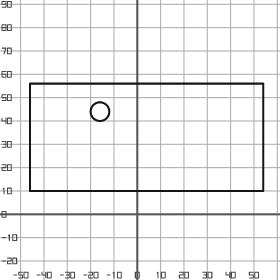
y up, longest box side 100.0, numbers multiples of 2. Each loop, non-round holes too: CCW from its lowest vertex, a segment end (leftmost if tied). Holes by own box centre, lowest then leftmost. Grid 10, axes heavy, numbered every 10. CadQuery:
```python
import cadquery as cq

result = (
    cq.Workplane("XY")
    .moveTo(-46.0, 10.0)
    .lineTo(54.0, 10.0)
    .lineTo(54.0, 56.0)
    .lineTo(-46.0, 56.0)
    .close()
    .moveTo(-16.0, 44.0)
    .circle(4.0)
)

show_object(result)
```